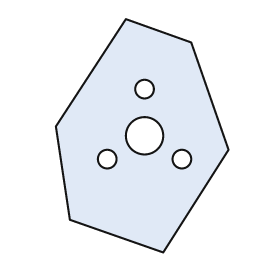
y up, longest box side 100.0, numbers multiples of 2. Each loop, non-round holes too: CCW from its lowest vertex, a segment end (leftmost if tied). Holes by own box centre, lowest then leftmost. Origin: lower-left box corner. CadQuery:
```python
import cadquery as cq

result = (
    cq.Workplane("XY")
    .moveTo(46.0, 0.0)
    .lineTo(74.0, 44.0)
    .lineTo(58.0, 90.0)
    .lineTo(30.0, 100.0)
    .lineTo(0.0, 54.0)
    .lineTo(6.0, 14.0)
    .close()
    .moveTo(22.0, 40.0)
    .circle(4.0)
    .moveTo(54.0, 40.0)
    .circle(4.0)
    .moveTo(38.0, 50.0)
    .circle(8.0)
    .moveTo(38.0, 70.0)
    .circle(4.0)
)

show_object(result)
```